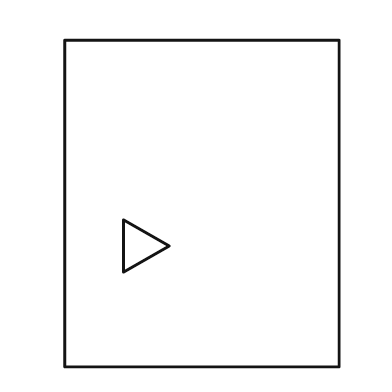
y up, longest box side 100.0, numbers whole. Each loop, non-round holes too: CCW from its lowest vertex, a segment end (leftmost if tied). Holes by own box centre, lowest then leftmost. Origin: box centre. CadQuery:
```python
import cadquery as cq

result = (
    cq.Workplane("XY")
    .moveTo(-42.0, -50.0)
    .lineTo(42.0, -50.0)
    .lineTo(42.0, 50.0)
    .lineTo(-42.0, 50.0)
    .close()
    .moveTo(-24.0, -21.0)
    .lineTo(-10.0, -13.0)
    .lineTo(-24.0, -5.0)
    .close()
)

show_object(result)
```